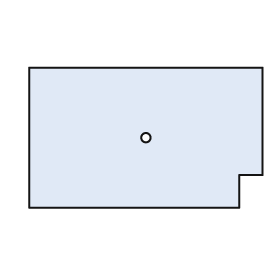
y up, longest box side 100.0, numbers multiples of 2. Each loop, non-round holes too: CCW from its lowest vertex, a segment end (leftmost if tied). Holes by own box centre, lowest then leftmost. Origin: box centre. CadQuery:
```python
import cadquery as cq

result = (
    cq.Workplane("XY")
    .moveTo(-50.0, -30.0)
    .lineTo(40.0, -30.0)
    .lineTo(40.0, -16.0)
    .lineTo(50.0, -16.0)
    .lineTo(50.0, 30.0)
    .lineTo(-50.0, 30.0)
    .close()
    .moveTo(0.0, 0.0)
    .circle(2.0)
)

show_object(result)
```